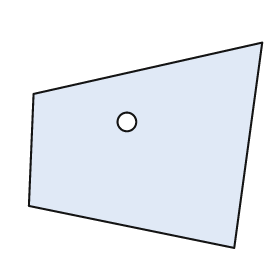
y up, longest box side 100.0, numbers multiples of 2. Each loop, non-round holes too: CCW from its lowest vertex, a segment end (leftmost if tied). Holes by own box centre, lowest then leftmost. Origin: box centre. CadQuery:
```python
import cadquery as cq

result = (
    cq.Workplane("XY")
    .moveTo(38.0, -44.0)
    .lineTo(50.0, 44.0)
    .lineTo(-48.0, 22.0)
    .lineTo(-50.0, -26.0)
    .close()
    .moveTo(-8.0, 10.0)
    .circle(4.0)
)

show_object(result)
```